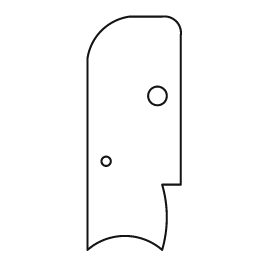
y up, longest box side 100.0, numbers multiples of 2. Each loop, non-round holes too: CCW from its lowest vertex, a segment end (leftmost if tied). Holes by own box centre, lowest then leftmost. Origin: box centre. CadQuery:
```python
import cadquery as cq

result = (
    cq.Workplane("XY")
    .moveTo(-20.0, -50.0)
    .threePointArc((-4.0, -44.0), (12.0, -50.0))
    .threePointArc((14.0, -36.0), (12.0, -22.0))
    .lineTo(20.0, -22.0)
    .lineTo(20.0, 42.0)
    .threePointArc((18.0, 48.0), (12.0, 50.0))
    .lineTo(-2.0, 50.0)
    .threePointArc((-14.0, 44.0), (-20.0, 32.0))
    .close()
    .moveTo(-12.0, -12.0)
    .circle(2.0)
    .moveTo(10.0, 16.0)
    .circle(4.0)
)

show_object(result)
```